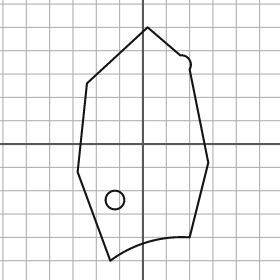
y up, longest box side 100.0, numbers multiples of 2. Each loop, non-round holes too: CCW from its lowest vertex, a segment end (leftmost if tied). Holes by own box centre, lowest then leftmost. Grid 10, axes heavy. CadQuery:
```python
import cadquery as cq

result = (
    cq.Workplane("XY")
    .moveTo(-14.0, -50.0)
    .threePointArc((2.0, -42.0), (20.0, -40.0))
    .lineTo(28.0, -8.0)
    .lineTo(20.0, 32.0)
    .threePointArc((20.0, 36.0), (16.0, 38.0))
    .lineTo(2.0, 50.0)
    .lineTo(-24.0, 26.0)
    .lineTo(-28.0, -12.0)
    .close()
    .moveTo(-12.0, -24.0)
    .circle(4.0)
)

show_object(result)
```